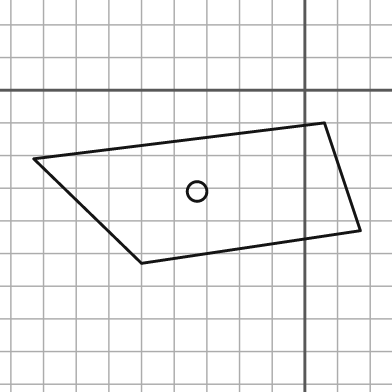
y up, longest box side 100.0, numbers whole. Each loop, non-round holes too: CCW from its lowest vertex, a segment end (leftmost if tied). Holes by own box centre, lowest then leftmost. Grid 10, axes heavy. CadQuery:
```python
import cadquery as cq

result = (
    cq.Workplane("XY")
    .moveTo(-50.0, -53.0)
    .lineTo(17.0, -43.0)
    .lineTo(6.0, -10.0)
    .lineTo(-83.0, -21.0)
    .close()
    .moveTo(-33.0, -31.0)
    .circle(3.0)
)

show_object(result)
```